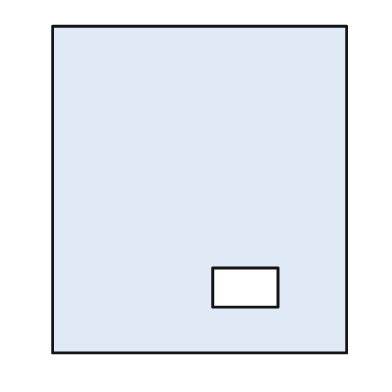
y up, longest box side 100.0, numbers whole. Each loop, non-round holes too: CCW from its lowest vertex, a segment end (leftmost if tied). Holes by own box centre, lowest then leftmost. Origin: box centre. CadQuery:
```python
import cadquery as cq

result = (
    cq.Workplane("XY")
    .moveTo(-45.0, -50.0)
    .lineTo(45.0, -50.0)
    .lineTo(45.0, 50.0)
    .lineTo(-45.0, 50.0)
    .close()
    .moveTo(4.0, -36.0)
    .lineTo(24.0, -36.0)
    .lineTo(24.0, -24.0)
    .lineTo(4.0, -24.0)
    .close()
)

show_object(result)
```